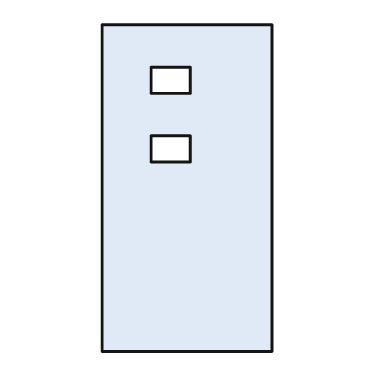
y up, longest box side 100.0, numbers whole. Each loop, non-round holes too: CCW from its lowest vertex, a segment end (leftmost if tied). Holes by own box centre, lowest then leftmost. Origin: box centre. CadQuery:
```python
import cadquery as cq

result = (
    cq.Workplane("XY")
    .moveTo(-26.0, -50.0)
    .lineTo(26.0, -50.0)
    .lineTo(26.0, 50.0)
    .lineTo(-26.0, 50.0)
    .close()
    .moveTo(-11.0, 8.0)
    .lineTo(1.0, 8.0)
    .lineTo(1.0, 16.0)
    .lineTo(-11.0, 16.0)
    .close()
    .moveTo(-11.0, 29.0)
    .lineTo(1.0, 29.0)
    .lineTo(1.0, 37.0)
    .lineTo(-11.0, 37.0)
    .close()
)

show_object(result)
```